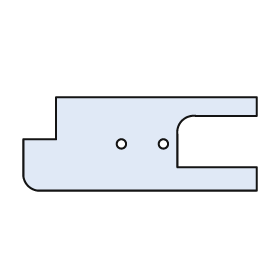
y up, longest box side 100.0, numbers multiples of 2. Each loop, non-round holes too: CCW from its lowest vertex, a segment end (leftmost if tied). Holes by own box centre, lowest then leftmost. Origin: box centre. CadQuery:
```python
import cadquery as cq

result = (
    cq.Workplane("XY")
    .moveTo(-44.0, -20.0)
    .lineTo(50.0, -20.0)
    .lineTo(50.0, -10.0)
    .lineTo(16.0, -10.0)
    .lineTo(16.0, 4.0)
    .threePointArc((18.0, 10.0), (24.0, 12.0))
    .lineTo(50.0, 12.0)
    .lineTo(50.0, 20.0)
    .lineTo(-36.0, 20.0)
    .lineTo(-36.0, 2.0)
    .lineTo(-50.0, 2.0)
    .lineTo(-50.0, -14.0)
    .threePointArc((-48.0, -18.0), (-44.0, -20.0))
    .close()
    .moveTo(-8.0, 0.0)
    .circle(2.0)
    .moveTo(10.0, 0.0)
    .circle(2.0)
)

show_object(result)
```